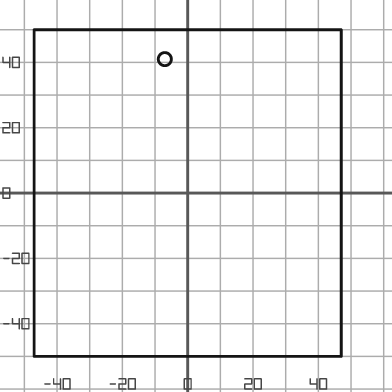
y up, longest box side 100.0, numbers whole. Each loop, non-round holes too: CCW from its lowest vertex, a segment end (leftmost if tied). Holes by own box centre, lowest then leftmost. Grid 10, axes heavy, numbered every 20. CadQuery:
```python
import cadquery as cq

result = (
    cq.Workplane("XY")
    .moveTo(-47.0, -50.0)
    .lineTo(47.0, -50.0)
    .lineTo(47.0, 50.0)
    .lineTo(-47.0, 50.0)
    .close()
    .moveTo(-7.0, 41.0)
    .circle(2.0)
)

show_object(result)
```